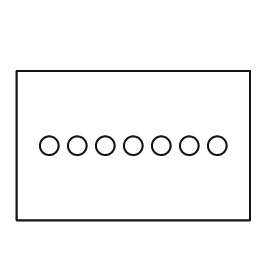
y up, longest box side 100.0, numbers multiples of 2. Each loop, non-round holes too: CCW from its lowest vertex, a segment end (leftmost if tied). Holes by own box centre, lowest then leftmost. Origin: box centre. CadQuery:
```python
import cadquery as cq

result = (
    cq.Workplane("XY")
    .moveTo(-50.0, -32.0)
    .lineTo(50.0, -32.0)
    .lineTo(50.0, 32.0)
    .lineTo(-50.0, 32.0)
    .close()
    .moveTo(-36.0, 0.0)
    .circle(4.0)
    .moveTo(-24.0, 0.0)
    .circle(4.0)
    .moveTo(-12.0, 0.0)
    .circle(4.0)
    .moveTo(0.0, 0.0)
    .circle(4.0)
    .moveTo(12.0, 0.0)
    .circle(4.0)
    .moveTo(24.0, 0.0)
    .circle(4.0)
    .moveTo(36.0, 0.0)
    .circle(4.0)
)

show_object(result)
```